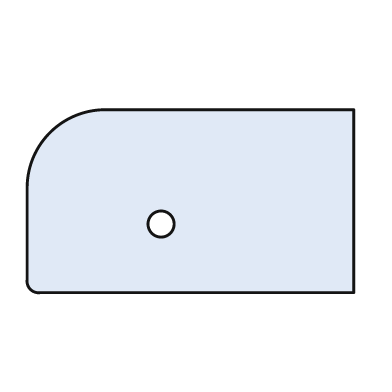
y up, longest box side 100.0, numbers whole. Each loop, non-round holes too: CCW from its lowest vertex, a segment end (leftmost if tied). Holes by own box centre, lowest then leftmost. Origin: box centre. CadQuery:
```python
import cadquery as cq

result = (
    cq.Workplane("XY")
    .moveTo(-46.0, -28.0)
    .lineTo(50.0, -28.0)
    .lineTo(50.0, 28.0)
    .lineTo(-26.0, 28.0)
    .threePointArc((-43.0, 21.0), (-50.0, 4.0))
    .lineTo(-50.0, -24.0)
    .threePointArc((-49.0, -27.0), (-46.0, -28.0))
    .close()
    .moveTo(-9.0, -7.0)
    .circle(4.0)
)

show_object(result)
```